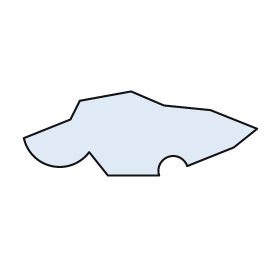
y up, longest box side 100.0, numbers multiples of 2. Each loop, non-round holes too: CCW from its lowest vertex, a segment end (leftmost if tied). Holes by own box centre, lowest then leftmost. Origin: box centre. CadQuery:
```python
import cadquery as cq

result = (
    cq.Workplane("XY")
    .moveTo(-14.0, -18.0)
    .lineTo(8.0, -18.0)
    .threePointArc((12.0, -10.0), (20.0, -14.0))
    .lineTo(40.0, -6.0)
    .lineTo(50.0, 2.0)
    .lineTo(30.0, 10.0)
    .lineTo(10.0, 12.0)
    .lineTo(-4.0, 18.0)
    .lineTo(-26.0, 14.0)
    .lineTo(-30.0, 6.0)
    .lineTo(-50.0, -2.0)
    .threePointArc((-38.0, -14.0), (-22.0, -8.0))
    .close()
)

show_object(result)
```